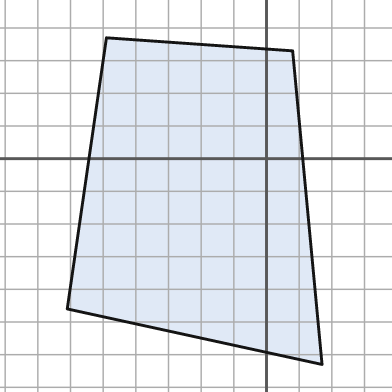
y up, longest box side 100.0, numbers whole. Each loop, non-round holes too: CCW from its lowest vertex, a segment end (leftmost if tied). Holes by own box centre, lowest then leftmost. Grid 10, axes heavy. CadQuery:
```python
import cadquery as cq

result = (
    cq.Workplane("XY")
    .moveTo(17.0, -63.0)
    .lineTo(8.0, 33.0)
    .lineTo(-49.0, 37.0)
    .lineTo(-61.0, -46.0)
    .close()
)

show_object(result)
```